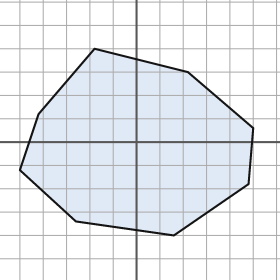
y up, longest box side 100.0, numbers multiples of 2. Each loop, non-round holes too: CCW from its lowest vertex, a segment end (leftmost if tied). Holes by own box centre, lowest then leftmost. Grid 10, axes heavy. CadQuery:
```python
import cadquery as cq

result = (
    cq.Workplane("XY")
    .moveTo(16.0, -40.0)
    .lineTo(48.0, -18.0)
    .lineTo(50.0, 6.0)
    .lineTo(22.0, 30.0)
    .lineTo(-18.0, 40.0)
    .lineTo(-42.0, 12.0)
    .lineTo(-50.0, -12.0)
    .lineTo(-26.0, -34.0)
    .close()
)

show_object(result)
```